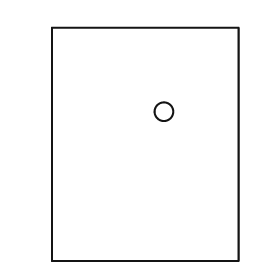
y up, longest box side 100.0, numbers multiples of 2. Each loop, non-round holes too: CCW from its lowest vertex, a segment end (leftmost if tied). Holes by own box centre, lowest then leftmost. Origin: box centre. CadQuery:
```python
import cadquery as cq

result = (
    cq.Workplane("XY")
    .moveTo(-40.0, -50.0)
    .lineTo(40.0, -50.0)
    .lineTo(40.0, 50.0)
    .lineTo(-40.0, 50.0)
    .close()
    .moveTo(8.0, 14.0)
    .circle(4.0)
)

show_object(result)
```